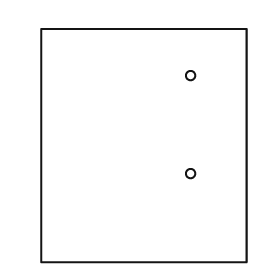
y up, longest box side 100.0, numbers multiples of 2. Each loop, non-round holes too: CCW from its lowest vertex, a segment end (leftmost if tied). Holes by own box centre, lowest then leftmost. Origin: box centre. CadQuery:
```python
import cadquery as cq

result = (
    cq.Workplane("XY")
    .moveTo(-44.0, -50.0)
    .lineTo(44.0, -50.0)
    .lineTo(44.0, 50.0)
    .lineTo(-44.0, 50.0)
    .close()
    .moveTo(20.0, -12.0)
    .circle(2.0)
    .moveTo(20.0, 30.0)
    .circle(2.0)
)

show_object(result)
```